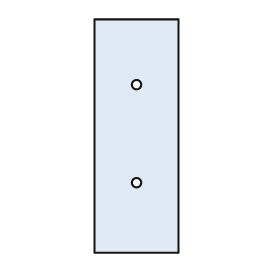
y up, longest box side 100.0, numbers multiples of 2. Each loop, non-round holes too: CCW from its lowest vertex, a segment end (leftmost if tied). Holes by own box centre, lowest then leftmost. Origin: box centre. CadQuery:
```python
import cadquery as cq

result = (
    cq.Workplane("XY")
    .moveTo(-18.0, -50.0)
    .lineTo(18.0, -50.0)
    .lineTo(18.0, 50.0)
    .lineTo(-18.0, 50.0)
    .close()
    .moveTo(0.0, -20.0)
    .circle(2.0)
    .moveTo(0.0, 22.0)
    .circle(2.0)
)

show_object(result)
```